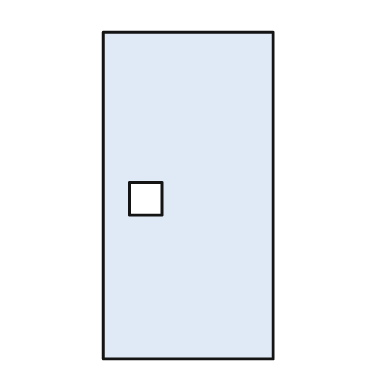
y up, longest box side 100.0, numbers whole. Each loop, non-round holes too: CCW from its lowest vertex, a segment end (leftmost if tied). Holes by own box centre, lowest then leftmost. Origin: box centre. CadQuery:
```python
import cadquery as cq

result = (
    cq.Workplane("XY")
    .moveTo(-26.0, -50.0)
    .lineTo(26.0, -50.0)
    .lineTo(26.0, 50.0)
    .lineTo(-26.0, 50.0)
    .close()
    .moveTo(-18.0, -6.0)
    .lineTo(-8.0, -6.0)
    .lineTo(-8.0, 4.0)
    .lineTo(-18.0, 4.0)
    .close()
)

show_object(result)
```